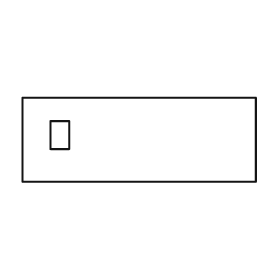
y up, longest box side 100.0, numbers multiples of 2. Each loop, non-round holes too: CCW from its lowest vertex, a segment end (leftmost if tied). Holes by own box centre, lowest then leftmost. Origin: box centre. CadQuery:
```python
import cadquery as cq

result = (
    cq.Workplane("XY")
    .moveTo(-50.0, -18.0)
    .lineTo(50.0, -18.0)
    .lineTo(50.0, 18.0)
    .lineTo(-50.0, 18.0)
    .close()
    .moveTo(-38.0, -4.0)
    .lineTo(-30.0, -4.0)
    .lineTo(-30.0, 8.0)
    .lineTo(-38.0, 8.0)
    .close()
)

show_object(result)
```